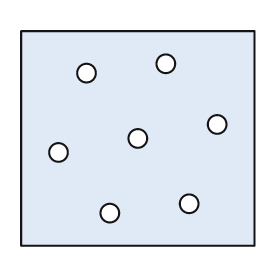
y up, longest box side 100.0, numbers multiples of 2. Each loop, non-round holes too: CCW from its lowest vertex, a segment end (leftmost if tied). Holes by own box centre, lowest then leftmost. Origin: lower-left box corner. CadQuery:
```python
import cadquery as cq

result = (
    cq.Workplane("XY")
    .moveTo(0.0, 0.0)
    .lineTo(100.0, 0.0)
    .lineTo(100.0, 92.0)
    .lineTo(0.0, 92.0)
    .close()
    .moveTo(38.0, 14.0)
    .circle(4.0)
    .moveTo(72.0, 18.0)
    .circle(4.0)
    .moveTo(16.0, 40.0)
    .circle(4.0)
    .moveTo(50.0, 46.0)
    .circle(4.0)
    .moveTo(84.0, 52.0)
    .circle(4.0)
    .moveTo(28.0, 74.0)
    .circle(4.0)
    .moveTo(62.0, 78.0)
    .circle(4.0)
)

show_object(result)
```